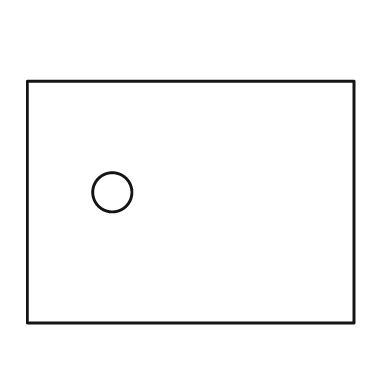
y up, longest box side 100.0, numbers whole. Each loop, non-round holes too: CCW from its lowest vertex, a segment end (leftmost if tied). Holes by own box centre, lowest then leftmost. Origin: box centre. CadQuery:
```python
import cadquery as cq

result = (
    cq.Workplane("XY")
    .moveTo(-50.0, -37.0)
    .lineTo(50.0, -37.0)
    .lineTo(50.0, 37.0)
    .lineTo(-50.0, 37.0)
    .close()
    .moveTo(-24.0, 3.0)
    .circle(6.0)
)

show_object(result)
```